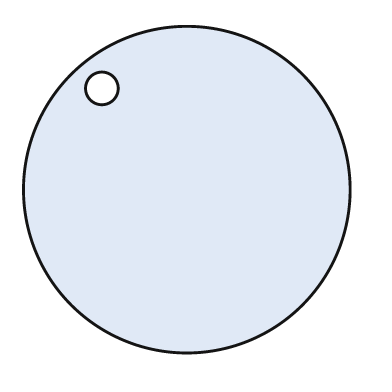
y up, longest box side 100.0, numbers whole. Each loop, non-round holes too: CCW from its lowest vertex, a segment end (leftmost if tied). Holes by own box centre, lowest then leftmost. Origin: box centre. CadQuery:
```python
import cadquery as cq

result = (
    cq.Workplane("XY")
    .moveTo(0.0, 0.0)
    .circle(50.0)
    .moveTo(-26.0, 31.0)
    .circle(5.0)
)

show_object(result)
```